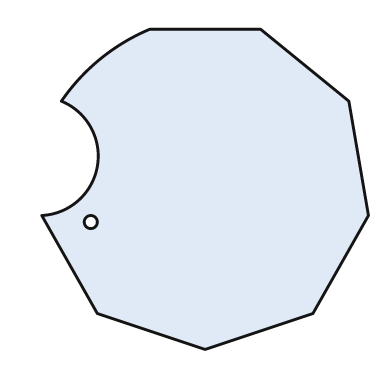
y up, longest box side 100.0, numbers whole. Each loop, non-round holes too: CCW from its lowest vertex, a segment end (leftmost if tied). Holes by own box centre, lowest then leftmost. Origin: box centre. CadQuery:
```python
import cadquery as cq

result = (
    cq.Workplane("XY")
    .moveTo(0.0, -49.0)
    .lineTo(33.0, -38.0)
    .lineTo(50.0, -8.0)
    .lineTo(44.0, 27.0)
    .lineTo(17.0, 49.0)
    .lineTo(-17.0, 49.0)
    .threePointArc((-32.0, 40.0), (-44.0, 27.0))
    .threePointArc((-33.0, 7.0), (-50.0, -8.0))
    .lineTo(-33.0, -38.0)
    .close()
    .moveTo(-35.0, -10.0)
    .circle(2.0)
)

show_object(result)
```